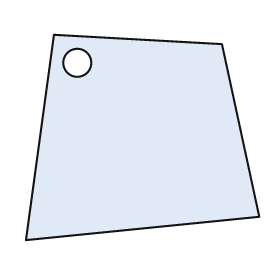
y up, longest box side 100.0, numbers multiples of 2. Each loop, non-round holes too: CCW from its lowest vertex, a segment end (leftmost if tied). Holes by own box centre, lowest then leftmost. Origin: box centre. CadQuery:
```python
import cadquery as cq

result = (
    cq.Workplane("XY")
    .moveTo(-50.0, -44.0)
    .lineTo(50.0, -34.0)
    .lineTo(34.0, 40.0)
    .lineTo(-38.0, 44.0)
    .close()
    .moveTo(-28.0, 32.0)
    .circle(6.0)
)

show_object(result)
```